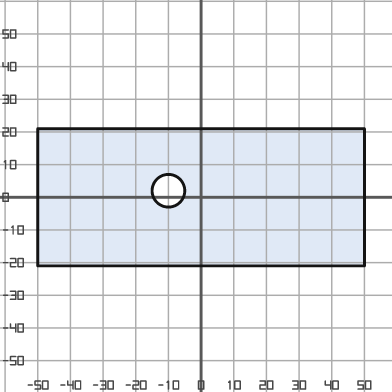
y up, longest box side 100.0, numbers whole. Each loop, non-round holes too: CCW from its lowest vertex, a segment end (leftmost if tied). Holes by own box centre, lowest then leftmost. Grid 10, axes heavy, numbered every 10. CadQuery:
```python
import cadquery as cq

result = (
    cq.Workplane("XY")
    .moveTo(-50.0, -21.0)
    .lineTo(50.0, -21.0)
    .lineTo(50.0, 21.0)
    .lineTo(-50.0, 21.0)
    .close()
    .moveTo(-10.0, 2.0)
    .circle(5.0)
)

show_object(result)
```